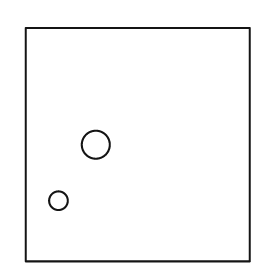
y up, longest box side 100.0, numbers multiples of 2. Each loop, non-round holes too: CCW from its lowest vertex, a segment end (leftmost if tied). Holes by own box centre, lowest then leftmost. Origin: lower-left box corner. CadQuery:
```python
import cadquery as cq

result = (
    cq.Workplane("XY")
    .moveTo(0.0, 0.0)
    .lineTo(96.0, 0.0)
    .lineTo(96.0, 100.0)
    .lineTo(0.0, 100.0)
    .close()
    .moveTo(14.0, 26.0)
    .circle(4.0)
    .moveTo(30.0, 50.0)
    .circle(6.0)
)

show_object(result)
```